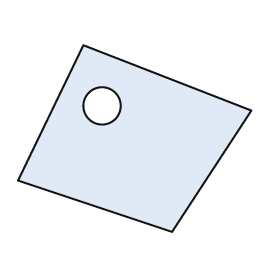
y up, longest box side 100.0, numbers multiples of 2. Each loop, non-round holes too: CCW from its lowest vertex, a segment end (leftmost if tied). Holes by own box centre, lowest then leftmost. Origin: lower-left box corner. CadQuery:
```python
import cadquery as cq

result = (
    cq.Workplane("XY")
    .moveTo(66.0, 0.0)
    .lineTo(100.0, 52.0)
    .lineTo(28.0, 80.0)
    .lineTo(0.0, 22.0)
    .close()
    .moveTo(36.0, 54.0)
    .circle(8.0)
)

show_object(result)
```